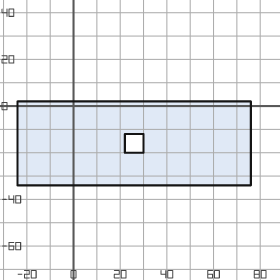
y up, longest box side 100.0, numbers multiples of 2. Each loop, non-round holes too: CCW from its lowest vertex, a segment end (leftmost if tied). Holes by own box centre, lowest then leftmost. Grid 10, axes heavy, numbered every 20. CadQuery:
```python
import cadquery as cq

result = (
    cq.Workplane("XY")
    .moveTo(-24.0, -34.0)
    .lineTo(76.0, -34.0)
    .lineTo(76.0, 2.0)
    .lineTo(-24.0, 2.0)
    .close()
    .moveTo(22.0, -20.0)
    .lineTo(30.0, -20.0)
    .lineTo(30.0, -12.0)
    .lineTo(22.0, -12.0)
    .close()
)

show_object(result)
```